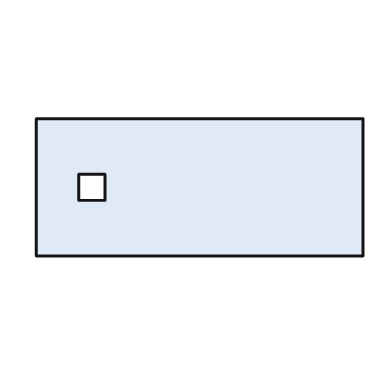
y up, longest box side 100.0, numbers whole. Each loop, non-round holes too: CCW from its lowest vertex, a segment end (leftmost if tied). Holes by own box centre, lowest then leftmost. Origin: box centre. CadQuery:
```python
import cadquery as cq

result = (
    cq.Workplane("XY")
    .moveTo(-50.0, -21.0)
    .lineTo(50.0, -21.0)
    .lineTo(50.0, 21.0)
    .lineTo(-50.0, 21.0)
    .close()
    .moveTo(-37.0, -4.0)
    .lineTo(-29.0, -4.0)
    .lineTo(-29.0, 4.0)
    .lineTo(-37.0, 4.0)
    .close()
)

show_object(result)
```